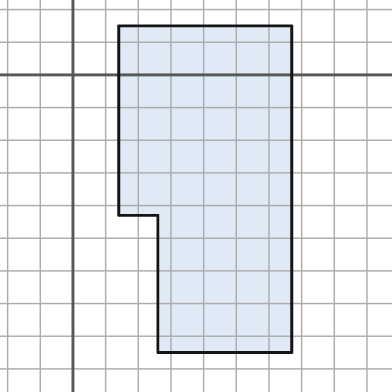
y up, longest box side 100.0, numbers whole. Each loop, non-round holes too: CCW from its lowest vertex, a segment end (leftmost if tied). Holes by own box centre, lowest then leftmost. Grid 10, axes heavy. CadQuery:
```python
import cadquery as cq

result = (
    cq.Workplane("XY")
    .moveTo(26.0, -85.0)
    .lineTo(67.0, -85.0)
    .lineTo(67.0, 15.0)
    .lineTo(14.0, 15.0)
    .lineTo(14.0, -43.0)
    .lineTo(26.0, -43.0)
    .close()
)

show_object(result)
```